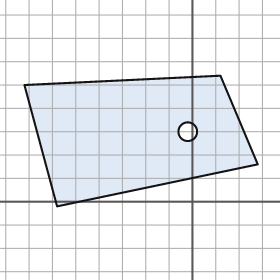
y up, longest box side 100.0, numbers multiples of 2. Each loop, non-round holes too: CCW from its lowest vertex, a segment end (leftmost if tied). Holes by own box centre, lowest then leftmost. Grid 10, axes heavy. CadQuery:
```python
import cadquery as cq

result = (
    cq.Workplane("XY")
    .moveTo(-58.0, -2.0)
    .lineTo(28.0, 16.0)
    .lineTo(12.0, 54.0)
    .lineTo(-72.0, 50.0)
    .close()
    .moveTo(-2.0, 30.0)
    .circle(4.0)
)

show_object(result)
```